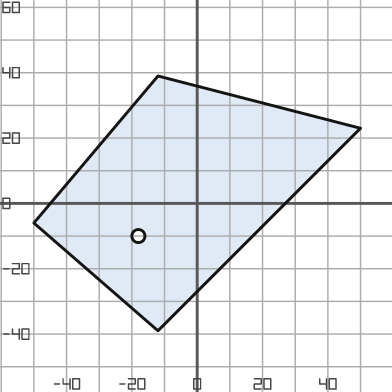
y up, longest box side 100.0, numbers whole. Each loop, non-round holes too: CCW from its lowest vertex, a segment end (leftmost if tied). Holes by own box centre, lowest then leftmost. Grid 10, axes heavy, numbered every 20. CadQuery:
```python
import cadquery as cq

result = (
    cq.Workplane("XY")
    .moveTo(-12.0, -39.0)
    .lineTo(50.0, 23.0)
    .lineTo(-12.0, 39.0)
    .lineTo(-50.0, -6.0)
    .close()
    .moveTo(-18.0, -10.0)
    .circle(2.0)
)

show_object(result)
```